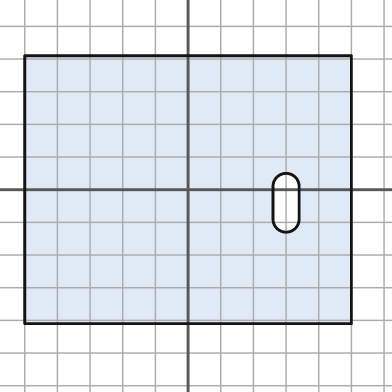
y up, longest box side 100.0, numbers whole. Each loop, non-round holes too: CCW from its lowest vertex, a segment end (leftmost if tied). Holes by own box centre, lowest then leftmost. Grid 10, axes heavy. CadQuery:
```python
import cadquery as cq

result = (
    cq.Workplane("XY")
    .moveTo(-50.0, -41.0)
    .lineTo(50.0, -41.0)
    .lineTo(50.0, 41.0)
    .lineTo(-50.0, 41.0)
    .close()
    .moveTo(26.0, -9.0)
    .threePointArc((30.0, -13.0), (34.0, -9.0))
    .lineTo(34.0, 1.0)
    .threePointArc((30.0, 5.0), (26.0, 1.0))
    .close()
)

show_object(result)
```